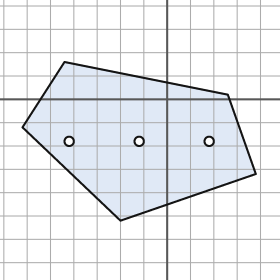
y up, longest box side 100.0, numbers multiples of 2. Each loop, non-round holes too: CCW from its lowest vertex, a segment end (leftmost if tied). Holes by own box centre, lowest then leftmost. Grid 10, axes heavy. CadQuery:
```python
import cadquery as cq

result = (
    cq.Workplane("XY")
    .moveTo(-20.0, -52.0)
    .lineTo(38.0, -32.0)
    .lineTo(26.0, 2.0)
    .lineTo(-44.0, 16.0)
    .lineTo(-62.0, -12.0)
    .close()
    .moveTo(-42.0, -18.0)
    .circle(2.0)
    .moveTo(-12.0, -18.0)
    .circle(2.0)
    .moveTo(18.0, -18.0)
    .circle(2.0)
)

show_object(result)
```